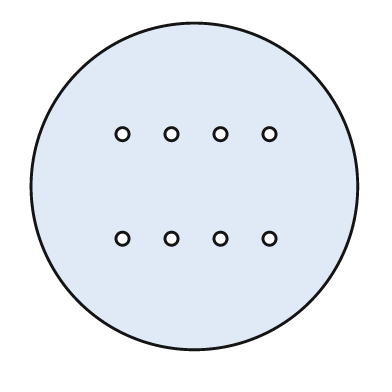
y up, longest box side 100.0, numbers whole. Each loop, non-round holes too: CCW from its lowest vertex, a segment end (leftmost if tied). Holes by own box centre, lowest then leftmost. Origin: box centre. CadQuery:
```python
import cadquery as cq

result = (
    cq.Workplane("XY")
    .moveTo(0.0, 0.0)
    .circle(50.0)
    .moveTo(-22.0, -16.0)
    .circle(2.0)
    .moveTo(-7.0, -16.0)
    .circle(2.0)
    .moveTo(8.0, -16.0)
    .circle(2.0)
    .moveTo(23.0, -16.0)
    .circle(2.0)
    .moveTo(-22.0, 16.0)
    .circle(2.0)
    .moveTo(-7.0, 16.0)
    .circle(2.0)
    .moveTo(8.0, 16.0)
    .circle(2.0)
    .moveTo(23.0, 16.0)
    .circle(2.0)
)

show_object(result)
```